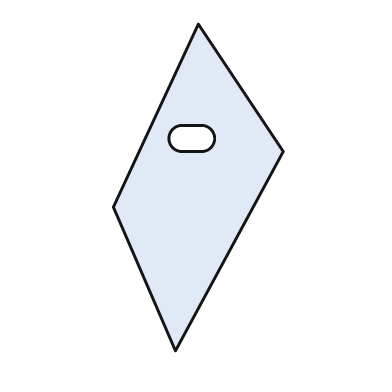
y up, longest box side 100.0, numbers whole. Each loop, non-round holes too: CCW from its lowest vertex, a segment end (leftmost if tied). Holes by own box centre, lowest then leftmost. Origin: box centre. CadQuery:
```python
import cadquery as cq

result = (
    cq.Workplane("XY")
    .moveTo(-7.0, -50.0)
    .lineTo(26.0, 11.0)
    .lineTo(0.0, 50.0)
    .lineTo(-26.0, -6.0)
    .close()
    .moveTo(-5.0, 11.0)
    .lineTo(1.0, 11.0)
    .threePointArc((5.0, 15.0), (1.0, 19.0))
    .lineTo(-5.0, 19.0)
    .threePointArc((-9.0, 15.0), (-5.0, 11.0))
    .close()
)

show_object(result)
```